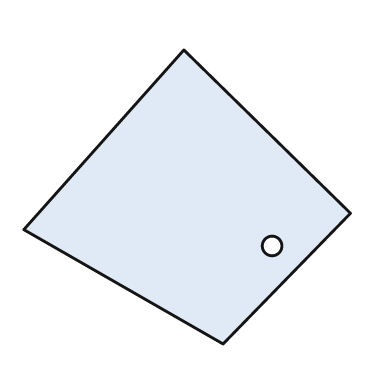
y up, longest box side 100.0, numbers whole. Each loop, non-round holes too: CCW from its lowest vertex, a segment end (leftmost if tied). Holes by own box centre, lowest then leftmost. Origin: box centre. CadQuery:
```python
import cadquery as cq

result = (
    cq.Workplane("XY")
    .moveTo(11.0, -45.0)
    .lineTo(50.0, -5.0)
    .lineTo(-1.0, 45.0)
    .lineTo(-50.0, -10.0)
    .close()
    .moveTo(26.0, -15.0)
    .circle(3.0)
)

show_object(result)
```